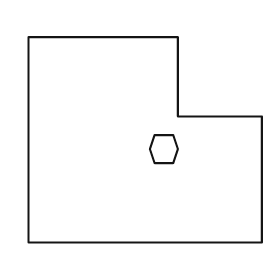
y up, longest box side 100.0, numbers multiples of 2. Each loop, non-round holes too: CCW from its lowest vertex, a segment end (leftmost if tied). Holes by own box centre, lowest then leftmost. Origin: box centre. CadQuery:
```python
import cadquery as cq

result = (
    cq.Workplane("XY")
    .moveTo(-50.0, -44.0)
    .lineTo(50.0, -44.0)
    .lineTo(50.0, 10.0)
    .lineTo(14.0, 10.0)
    .lineTo(14.0, 44.0)
    .lineTo(-50.0, 44.0)
    .close()
    .moveTo(4.0, -10.0)
    .lineTo(12.0, -10.0)
    .lineTo(14.0, -4.0)
    .lineTo(12.0, 2.0)
    .lineTo(4.0, 2.0)
    .lineTo(2.0, -4.0)
    .close()
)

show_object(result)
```